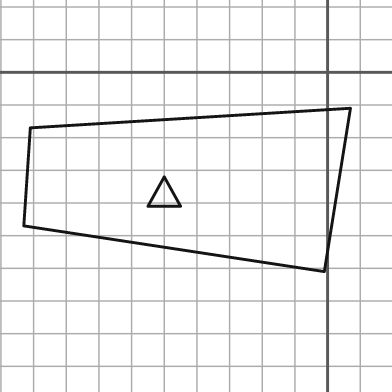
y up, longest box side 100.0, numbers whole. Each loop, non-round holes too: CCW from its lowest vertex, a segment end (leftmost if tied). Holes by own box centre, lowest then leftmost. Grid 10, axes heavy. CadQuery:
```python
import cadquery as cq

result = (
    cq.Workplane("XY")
    .moveTo(-1.0, -61.0)
    .lineTo(7.0, -11.0)
    .lineTo(-91.0, -17.0)
    .lineTo(-93.0, -47.0)
    .close()
    .moveTo(-55.0, -41.0)
    .lineTo(-45.0, -41.0)
    .lineTo(-50.0, -32.0)
    .close()
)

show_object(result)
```